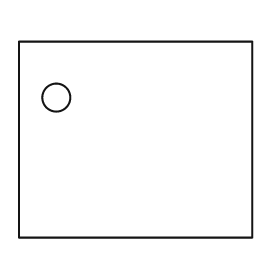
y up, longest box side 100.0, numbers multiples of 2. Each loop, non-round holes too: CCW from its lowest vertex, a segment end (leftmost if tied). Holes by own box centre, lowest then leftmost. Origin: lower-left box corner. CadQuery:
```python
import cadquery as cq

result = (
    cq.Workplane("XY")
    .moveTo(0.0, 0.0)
    .lineTo(100.0, 0.0)
    .lineTo(100.0, 84.0)
    .lineTo(0.0, 84.0)
    .close()
    .moveTo(16.0, 60.0)
    .circle(6.0)
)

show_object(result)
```